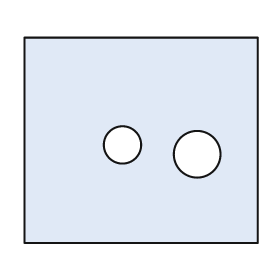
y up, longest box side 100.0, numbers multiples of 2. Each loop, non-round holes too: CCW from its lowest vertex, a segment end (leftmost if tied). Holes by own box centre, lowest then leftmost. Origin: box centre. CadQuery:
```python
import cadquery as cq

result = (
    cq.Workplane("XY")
    .moveTo(-50.0, -44.0)
    .lineTo(50.0, -44.0)
    .lineTo(50.0, 44.0)
    .lineTo(-50.0, 44.0)
    .close()
    .moveTo(24.0, -6.0)
    .circle(10.0)
    .moveTo(-8.0, -2.0)
    .circle(8.0)
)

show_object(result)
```